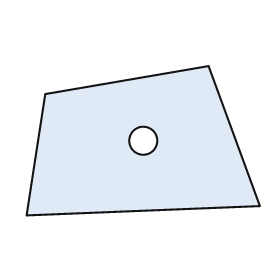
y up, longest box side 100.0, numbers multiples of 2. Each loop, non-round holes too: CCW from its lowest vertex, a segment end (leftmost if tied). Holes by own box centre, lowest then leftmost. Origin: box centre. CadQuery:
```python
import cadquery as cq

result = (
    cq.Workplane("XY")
    .moveTo(-50.0, -32.0)
    .lineTo(50.0, -28.0)
    .lineTo(28.0, 32.0)
    .lineTo(-42.0, 20.0)
    .close()
    .moveTo(0.0, 0.0)
    .circle(6.0)
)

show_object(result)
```